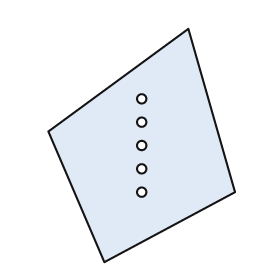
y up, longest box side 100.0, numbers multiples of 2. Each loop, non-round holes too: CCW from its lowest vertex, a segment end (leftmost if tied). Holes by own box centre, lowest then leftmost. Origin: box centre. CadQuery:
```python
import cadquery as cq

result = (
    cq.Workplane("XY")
    .moveTo(-16.0, -50.0)
    .lineTo(40.0, -20.0)
    .lineTo(20.0, 50.0)
    .lineTo(-40.0, 6.0)
    .close()
    .moveTo(0.0, -20.0)
    .circle(2.0)
    .moveTo(0.0, -10.0)
    .circle(2.0)
    .moveTo(0.0, 0.0)
    .circle(2.0)
    .moveTo(0.0, 10.0)
    .circle(2.0)
    .moveTo(0.0, 20.0)
    .circle(2.0)
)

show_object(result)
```